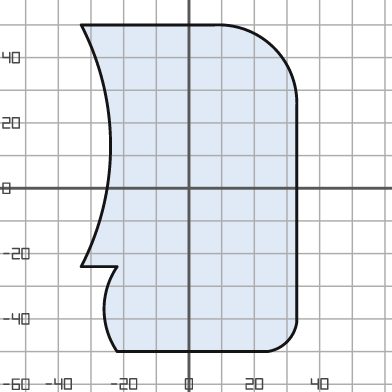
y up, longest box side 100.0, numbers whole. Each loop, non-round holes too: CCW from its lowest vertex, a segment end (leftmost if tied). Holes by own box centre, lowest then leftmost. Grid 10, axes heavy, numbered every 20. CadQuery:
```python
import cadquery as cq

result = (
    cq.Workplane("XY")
    .moveTo(-22.0, -50.0)
    .lineTo(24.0, -50.0)
    .threePointArc((30.0, -47.0), (33.0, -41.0))
    .lineTo(33.0, 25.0)
    .threePointArc((26.0, 43.0), (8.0, 50.0))
    .lineTo(-33.0, 50.0)
    .threePointArc((-24.0, 13.0), (-33.0, -24.0))
    .lineTo(-22.0, -24.0)
    .threePointArc((-26.0, -37.0), (-22.0, -50.0))
    .close()
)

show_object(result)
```